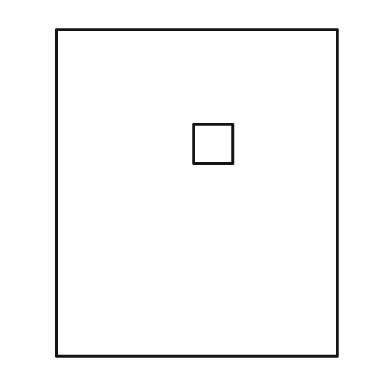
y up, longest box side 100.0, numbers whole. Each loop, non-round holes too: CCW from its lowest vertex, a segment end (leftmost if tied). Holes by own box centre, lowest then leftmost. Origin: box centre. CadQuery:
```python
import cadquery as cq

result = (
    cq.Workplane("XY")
    .moveTo(-43.0, -50.0)
    .lineTo(43.0, -50.0)
    .lineTo(43.0, 50.0)
    .lineTo(-43.0, 50.0)
    .close()
    .moveTo(-1.0, 9.0)
    .lineTo(11.0, 9.0)
    .lineTo(11.0, 21.0)
    .lineTo(-1.0, 21.0)
    .close()
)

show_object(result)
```